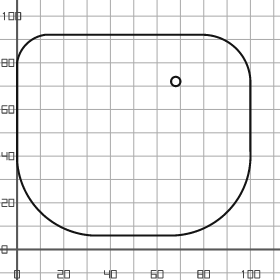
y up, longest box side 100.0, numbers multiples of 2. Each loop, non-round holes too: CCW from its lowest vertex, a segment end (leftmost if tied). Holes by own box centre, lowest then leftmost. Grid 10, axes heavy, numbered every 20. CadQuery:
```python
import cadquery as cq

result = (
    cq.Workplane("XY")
    .moveTo(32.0, 6.0)
    .lineTo(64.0, 6.0)
    .threePointArc((90.0, 16.0), (100.0, 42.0))
    .lineTo(100.0, 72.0)
    .threePointArc((94.0, 86.0), (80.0, 92.0))
    .lineTo(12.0, 92.0)
    .threePointArc((4.0, 88.0), (0.0, 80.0))
    .lineTo(0.0, 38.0)
    .threePointArc((10.0, 16.0), (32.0, 6.0))
    .close()
    .moveTo(68.0, 72.0)
    .circle(2.0)
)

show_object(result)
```